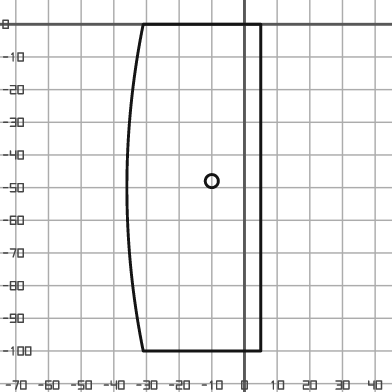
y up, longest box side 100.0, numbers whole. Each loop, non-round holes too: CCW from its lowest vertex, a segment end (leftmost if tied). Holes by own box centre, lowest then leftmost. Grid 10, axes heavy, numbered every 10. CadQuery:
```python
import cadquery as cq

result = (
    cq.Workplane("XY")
    .moveTo(-31.0, -100.0)
    .lineTo(5.0, -100.0)
    .lineTo(5.0, 0.0)
    .lineTo(-31.0, 0.0)
    .threePointArc((-36.0, -50.0), (-31.0, -100.0))
    .close()
    .moveTo(-10.0, -48.0)
    .circle(2.0)
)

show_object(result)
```